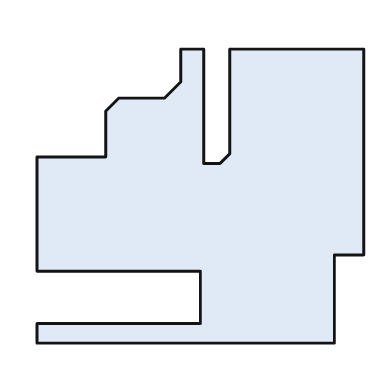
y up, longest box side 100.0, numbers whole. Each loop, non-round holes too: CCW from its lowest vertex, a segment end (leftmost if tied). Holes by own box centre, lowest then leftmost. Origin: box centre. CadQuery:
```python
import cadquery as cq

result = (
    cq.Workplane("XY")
    .moveTo(-50.0, -45.0)
    .lineTo(41.0, -45.0)
    .lineTo(41.0, -18.0)
    .lineTo(50.0, -18.0)
    .lineTo(50.0, 45.0)
    .lineTo(9.0, 45.0)
    .lineTo(9.0, 13.0)
    .lineTo(6.0, 10.0)
    .lineTo(1.0, 10.0)
    .lineTo(1.0, 45.0)
    .lineTo(-6.0, 45.0)
    .lineTo(-6.0, 35.0)
    .lineTo(-11.0, 30.0)
    .lineTo(-25.0, 30.0)
    .lineTo(-29.0, 26.0)
    .lineTo(-29.0, 12.0)
    .lineTo(-50.0, 12.0)
    .lineTo(-50.0, -23.0)
    .lineTo(0.0, -23.0)
    .lineTo(0.0, -39.0)
    .lineTo(-50.0, -39.0)
    .close()
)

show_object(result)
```